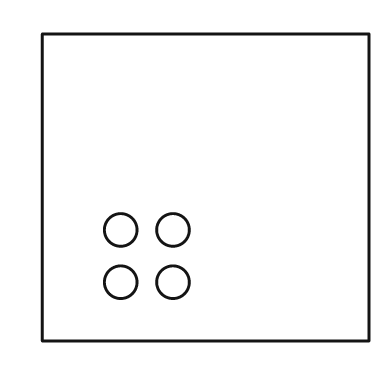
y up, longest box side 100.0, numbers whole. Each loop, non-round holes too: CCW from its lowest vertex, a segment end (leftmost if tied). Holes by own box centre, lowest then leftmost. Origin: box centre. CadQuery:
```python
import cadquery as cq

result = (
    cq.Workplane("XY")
    .moveTo(-50.0, -47.0)
    .lineTo(50.0, -47.0)
    .lineTo(50.0, 47.0)
    .lineTo(-50.0, 47.0)
    .close()
    .moveTo(-26.0, -29.0)
    .circle(5.0)
    .moveTo(-10.0, -29.0)
    .circle(5.0)
    .moveTo(-26.0, -13.0)
    .circle(5.0)
    .moveTo(-10.0, -13.0)
    .circle(5.0)
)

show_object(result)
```